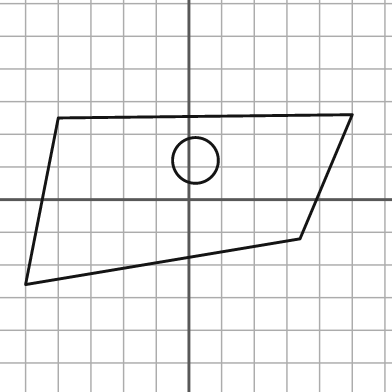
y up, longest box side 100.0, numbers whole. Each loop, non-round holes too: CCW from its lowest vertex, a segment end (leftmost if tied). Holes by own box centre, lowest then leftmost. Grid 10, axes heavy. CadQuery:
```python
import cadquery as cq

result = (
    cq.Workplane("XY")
    .moveTo(-50.0, -26.0)
    .lineTo(34.0, -12.0)
    .lineTo(50.0, 26.0)
    .lineTo(-40.0, 25.0)
    .close()
    .moveTo(2.0, 12.0)
    .circle(7.0)
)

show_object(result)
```